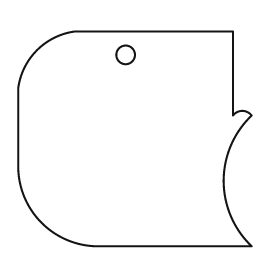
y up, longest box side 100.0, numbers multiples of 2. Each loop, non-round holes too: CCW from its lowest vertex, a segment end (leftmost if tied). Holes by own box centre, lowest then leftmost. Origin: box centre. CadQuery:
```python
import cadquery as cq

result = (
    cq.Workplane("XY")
    .moveTo(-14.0, -46.0)
    .lineTo(50.0, -46.0)
    .threePointArc((38.0, -18.0), (50.0, 10.0))
    .threePointArc((46.0, 12.0), (42.0, 10.0))
    .lineTo(42.0, 46.0)
    .lineTo(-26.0, 46.0)
    .threePointArc((-42.0, 38.0), (-50.0, 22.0))
    .lineTo(-50.0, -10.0)
    .threePointArc((-40.0, -36.0), (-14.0, -46.0))
    .close()
    .moveTo(-4.0, 36.0)
    .circle(4.0)
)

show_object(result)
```